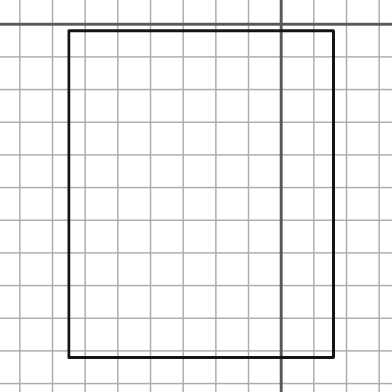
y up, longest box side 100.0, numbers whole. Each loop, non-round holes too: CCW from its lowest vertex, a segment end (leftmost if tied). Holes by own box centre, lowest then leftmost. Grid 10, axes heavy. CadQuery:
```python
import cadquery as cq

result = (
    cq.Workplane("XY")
    .moveTo(-65.0, -102.0)
    .lineTo(16.0, -102.0)
    .lineTo(16.0, -2.0)
    .lineTo(-65.0, -2.0)
    .close()
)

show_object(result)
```